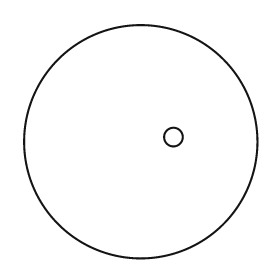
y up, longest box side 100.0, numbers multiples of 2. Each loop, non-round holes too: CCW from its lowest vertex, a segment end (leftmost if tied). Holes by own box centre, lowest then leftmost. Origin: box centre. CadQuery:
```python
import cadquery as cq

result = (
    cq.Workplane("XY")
    .moveTo(0.0, 0.0)
    .circle(50.0)
    .moveTo(14.0, 2.0)
    .circle(4.0)
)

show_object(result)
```